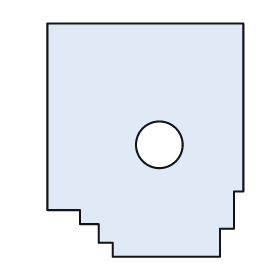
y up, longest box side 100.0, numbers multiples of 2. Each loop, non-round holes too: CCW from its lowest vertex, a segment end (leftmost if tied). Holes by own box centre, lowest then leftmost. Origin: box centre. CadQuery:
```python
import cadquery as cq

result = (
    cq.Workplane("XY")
    .moveTo(-14.0, -50.0)
    .lineTo(32.0, -50.0)
    .lineTo(32.0, -38.0)
    .lineTo(38.0, -38.0)
    .lineTo(38.0, -22.0)
    .lineTo(42.0, -22.0)
    .lineTo(42.0, 50.0)
    .lineTo(-42.0, 50.0)
    .lineTo(-42.0, -30.0)
    .lineTo(-28.0, -30.0)
    .lineTo(-28.0, -36.0)
    .lineTo(-20.0, -36.0)
    .lineTo(-20.0, -44.0)
    .lineTo(-14.0, -44.0)
    .close()
    .moveTo(6.0, -2.0)
    .circle(10.0)
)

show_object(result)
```